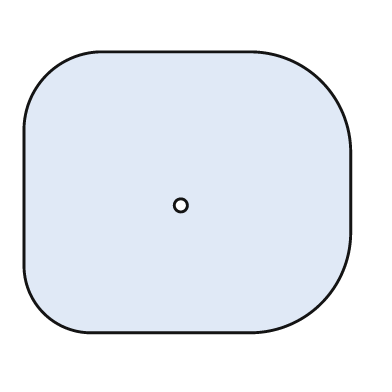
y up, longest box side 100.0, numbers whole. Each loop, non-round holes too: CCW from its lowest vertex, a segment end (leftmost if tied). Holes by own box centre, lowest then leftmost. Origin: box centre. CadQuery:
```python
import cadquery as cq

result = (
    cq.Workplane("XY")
    .moveTo(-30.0, -43.0)
    .lineTo(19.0, -43.0)
    .threePointArc((41.0, -34.0), (50.0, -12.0))
    .lineTo(50.0, 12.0)
    .threePointArc((41.0, 34.0), (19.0, 43.0))
    .lineTo(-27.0, 43.0)
    .threePointArc((-43.0, 36.0), (-50.0, 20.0))
    .lineTo(-50.0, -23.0)
    .threePointArc((-44.0, -37.0), (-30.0, -43.0))
    .close()
    .moveTo(-2.0, -4.0)
    .circle(2.0)
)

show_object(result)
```